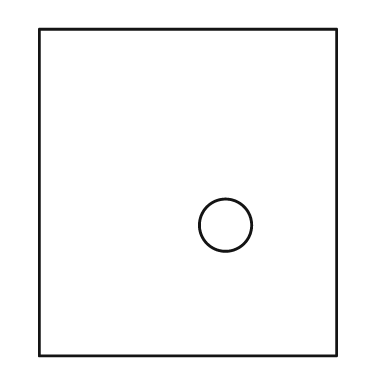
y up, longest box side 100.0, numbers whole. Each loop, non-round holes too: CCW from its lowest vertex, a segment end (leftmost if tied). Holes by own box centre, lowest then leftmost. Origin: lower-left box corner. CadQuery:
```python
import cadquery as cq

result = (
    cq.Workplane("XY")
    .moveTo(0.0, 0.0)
    .lineTo(91.0, 0.0)
    .lineTo(91.0, 100.0)
    .lineTo(0.0, 100.0)
    .close()
    .moveTo(57.0, 40.0)
    .circle(8.0)
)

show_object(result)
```